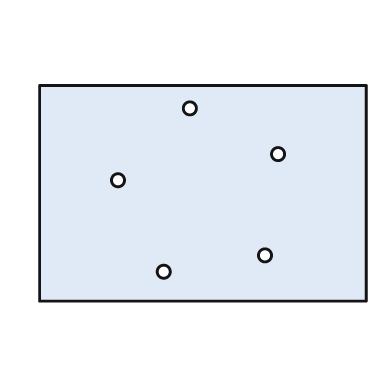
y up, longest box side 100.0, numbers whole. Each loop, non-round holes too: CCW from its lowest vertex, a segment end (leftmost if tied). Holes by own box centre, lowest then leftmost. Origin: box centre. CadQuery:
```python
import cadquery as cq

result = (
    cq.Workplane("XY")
    .moveTo(-50.0, -33.0)
    .lineTo(50.0, -33.0)
    .lineTo(50.0, 33.0)
    .lineTo(-50.0, 33.0)
    .close()
    .moveTo(-12.0, -24.0)
    .circle(2.0)
    .moveTo(19.0, -19.0)
    .circle(2.0)
    .moveTo(-26.0, 4.0)
    .circle(2.0)
    .moveTo(23.0, 12.0)
    .circle(2.0)
    .moveTo(-4.0, 26.0)
    .circle(2.0)
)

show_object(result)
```